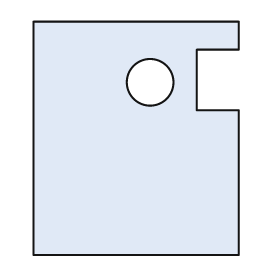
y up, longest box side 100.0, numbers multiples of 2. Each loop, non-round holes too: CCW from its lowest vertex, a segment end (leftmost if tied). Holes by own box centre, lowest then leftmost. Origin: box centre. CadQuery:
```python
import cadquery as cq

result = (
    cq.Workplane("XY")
    .moveTo(-44.0, -50.0)
    .lineTo(44.0, -50.0)
    .lineTo(44.0, 12.0)
    .lineTo(26.0, 12.0)
    .lineTo(26.0, 38.0)
    .lineTo(44.0, 38.0)
    .lineTo(44.0, 50.0)
    .lineTo(-44.0, 50.0)
    .close()
    .moveTo(6.0, 24.0)
    .circle(10.0)
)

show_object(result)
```